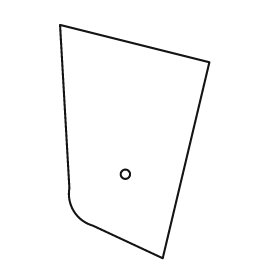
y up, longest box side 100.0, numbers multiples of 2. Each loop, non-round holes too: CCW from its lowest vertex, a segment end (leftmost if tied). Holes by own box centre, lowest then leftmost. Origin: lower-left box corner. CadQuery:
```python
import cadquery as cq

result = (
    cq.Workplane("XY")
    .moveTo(44.0, 0.0)
    .lineTo(64.0, 84.0)
    .lineTo(0.0, 100.0)
    .lineTo(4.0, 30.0)
    .threePointArc((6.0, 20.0), (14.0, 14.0))
    .close()
    .moveTo(28.0, 36.0)
    .circle(2.0)
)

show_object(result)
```